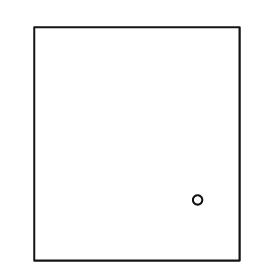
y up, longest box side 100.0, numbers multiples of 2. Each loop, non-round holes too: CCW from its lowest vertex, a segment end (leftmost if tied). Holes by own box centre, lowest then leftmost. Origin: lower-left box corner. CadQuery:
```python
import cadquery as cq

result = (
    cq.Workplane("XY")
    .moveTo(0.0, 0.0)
    .lineTo(88.0, 0.0)
    .lineTo(88.0, 100.0)
    .lineTo(0.0, 100.0)
    .close()
    .moveTo(70.0, 26.0)
    .circle(2.0)
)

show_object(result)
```